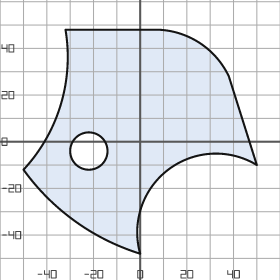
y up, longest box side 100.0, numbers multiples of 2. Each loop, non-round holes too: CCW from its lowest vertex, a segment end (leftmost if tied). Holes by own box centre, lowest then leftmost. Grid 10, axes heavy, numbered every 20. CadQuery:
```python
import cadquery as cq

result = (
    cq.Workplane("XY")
    .moveTo(0.0, -48.0)
    .threePointArc((12.0, -12.0), (50.0, -10.0))
    .lineTo(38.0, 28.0)
    .threePointArc((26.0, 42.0), (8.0, 48.0))
    .lineTo(-32.0, 48.0)
    .threePointArc((-34.0, 16.0), (-50.0, -12.0))
    .threePointArc((-28.0, -34.0), (0.0, -48.0))
    .close()
    .moveTo(-22.0, -4.0)
    .circle(8.0)
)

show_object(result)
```